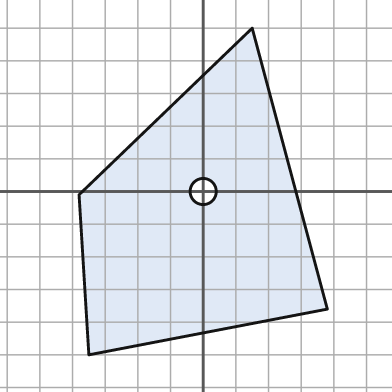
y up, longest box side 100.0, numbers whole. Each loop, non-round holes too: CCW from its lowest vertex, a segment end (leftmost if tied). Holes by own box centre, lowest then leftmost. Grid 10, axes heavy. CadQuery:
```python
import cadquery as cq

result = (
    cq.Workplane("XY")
    .moveTo(-35.0, -50.0)
    .lineTo(38.0, -36.0)
    .lineTo(15.0, 50.0)
    .lineTo(-38.0, -1.0)
    .close()
    .moveTo(0.0, 0.0)
    .circle(4.0)
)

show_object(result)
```